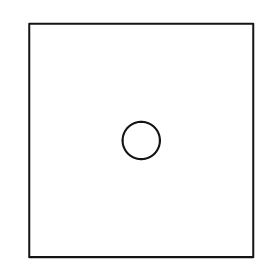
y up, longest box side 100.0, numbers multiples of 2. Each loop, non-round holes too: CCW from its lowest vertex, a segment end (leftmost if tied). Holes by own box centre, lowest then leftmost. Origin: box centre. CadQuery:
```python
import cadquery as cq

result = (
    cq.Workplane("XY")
    .moveTo(-48.0, -50.0)
    .lineTo(48.0, -50.0)
    .lineTo(48.0, 50.0)
    .lineTo(-48.0, 50.0)
    .close()
    .moveTo(0.0, 0.0)
    .circle(8.0)
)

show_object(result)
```